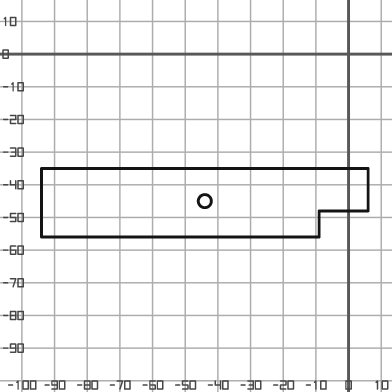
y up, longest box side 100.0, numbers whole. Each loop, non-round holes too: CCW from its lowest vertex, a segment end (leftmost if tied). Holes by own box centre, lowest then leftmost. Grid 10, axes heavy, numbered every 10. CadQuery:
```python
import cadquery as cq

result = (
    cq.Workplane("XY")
    .moveTo(-94.0, -56.0)
    .lineTo(-9.0, -56.0)
    .lineTo(-9.0, -48.0)
    .lineTo(6.0, -48.0)
    .lineTo(6.0, -35.0)
    .lineTo(-94.0, -35.0)
    .close()
    .moveTo(-44.0, -45.0)
    .circle(2.0)
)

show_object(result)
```